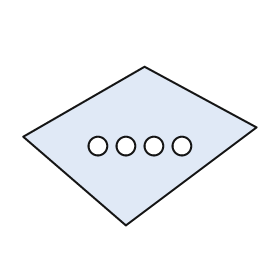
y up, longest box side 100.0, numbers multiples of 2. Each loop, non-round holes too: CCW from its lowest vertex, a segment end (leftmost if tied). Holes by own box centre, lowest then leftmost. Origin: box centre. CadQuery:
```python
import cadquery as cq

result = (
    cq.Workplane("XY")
    .moveTo(-6.0, -34.0)
    .lineTo(50.0, 8.0)
    .lineTo(2.0, 34.0)
    .lineTo(-50.0, 4.0)
    .close()
    .moveTo(-18.0, 0.0)
    .circle(4.0)
    .moveTo(-6.0, 0.0)
    .circle(4.0)
    .moveTo(6.0, 0.0)
    .circle(4.0)
    .moveTo(18.0, 0.0)
    .circle(4.0)
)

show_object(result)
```